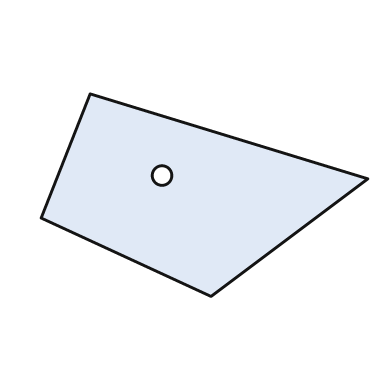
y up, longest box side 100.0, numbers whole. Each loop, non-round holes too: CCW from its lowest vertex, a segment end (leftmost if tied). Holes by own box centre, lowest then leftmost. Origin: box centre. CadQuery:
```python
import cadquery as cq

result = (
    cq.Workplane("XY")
    .moveTo(2.0, -31.0)
    .lineTo(50.0, 5.0)
    .lineTo(-35.0, 31.0)
    .lineTo(-50.0, -7.0)
    .close()
    .moveTo(-13.0, 6.0)
    .circle(3.0)
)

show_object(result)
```